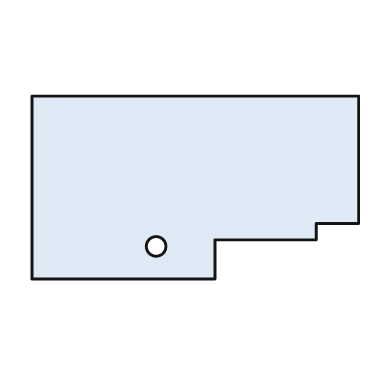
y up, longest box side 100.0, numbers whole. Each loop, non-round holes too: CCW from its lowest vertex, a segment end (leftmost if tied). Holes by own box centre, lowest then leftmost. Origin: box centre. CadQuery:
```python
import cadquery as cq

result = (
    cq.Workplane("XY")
    .moveTo(-50.0, -28.0)
    .lineTo(6.0, -28.0)
    .lineTo(6.0, -16.0)
    .lineTo(37.0, -16.0)
    .lineTo(37.0, -11.0)
    .lineTo(50.0, -11.0)
    .lineTo(50.0, 28.0)
    .lineTo(-50.0, 28.0)
    .close()
    .moveTo(-12.0, -18.0)
    .circle(3.0)
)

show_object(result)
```